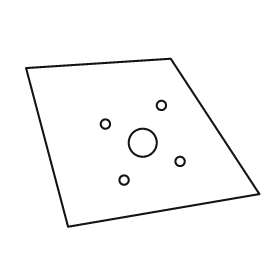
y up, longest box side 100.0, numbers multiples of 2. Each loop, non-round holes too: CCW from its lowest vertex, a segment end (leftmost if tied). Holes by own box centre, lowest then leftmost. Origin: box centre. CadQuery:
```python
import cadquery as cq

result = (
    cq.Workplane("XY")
    .moveTo(-32.0, -36.0)
    .lineTo(50.0, -22.0)
    .lineTo(12.0, 36.0)
    .lineTo(-50.0, 32.0)
    .close()
    .moveTo(-8.0, -16.0)
    .circle(2.0)
    .moveTo(16.0, -8.0)
    .circle(2.0)
    .moveTo(0.0, 0.0)
    .circle(6.0)
    .moveTo(-16.0, 8.0)
    .circle(2.0)
    .moveTo(8.0, 16.0)
    .circle(2.0)
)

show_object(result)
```